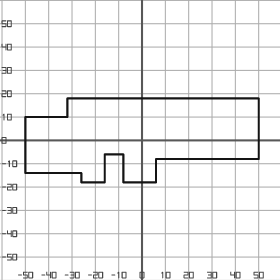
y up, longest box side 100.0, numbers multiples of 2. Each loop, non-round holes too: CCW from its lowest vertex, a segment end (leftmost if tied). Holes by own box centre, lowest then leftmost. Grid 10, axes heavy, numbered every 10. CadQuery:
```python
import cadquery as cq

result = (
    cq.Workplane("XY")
    .moveTo(-26.0, -18.0)
    .lineTo(-16.0, -18.0)
    .lineTo(-16.0, -6.0)
    .lineTo(-8.0, -6.0)
    .lineTo(-8.0, -18.0)
    .lineTo(6.0, -18.0)
    .lineTo(6.0, -8.0)
    .lineTo(50.0, -8.0)
    .lineTo(50.0, 18.0)
    .lineTo(-32.0, 18.0)
    .lineTo(-32.0, 10.0)
    .lineTo(-50.0, 10.0)
    .lineTo(-50.0, -14.0)
    .lineTo(-26.0, -14.0)
    .close()
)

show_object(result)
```